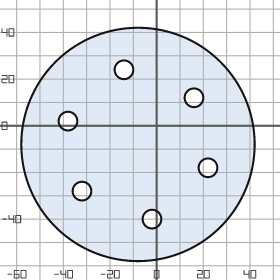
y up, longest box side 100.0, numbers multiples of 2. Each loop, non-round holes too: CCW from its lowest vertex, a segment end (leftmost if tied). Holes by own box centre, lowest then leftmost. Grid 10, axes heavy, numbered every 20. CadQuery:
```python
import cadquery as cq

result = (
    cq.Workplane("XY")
    .moveTo(-8.0, -8.0)
    .circle(50.0)
    .moveTo(-2.0, -40.0)
    .circle(4.0)
    .moveTo(-32.0, -28.0)
    .circle(4.0)
    .moveTo(22.0, -18.0)
    .circle(4.0)
    .moveTo(-38.0, 2.0)
    .circle(4.0)
    .moveTo(16.0, 12.0)
    .circle(4.0)
    .moveTo(-14.0, 24.0)
    .circle(4.0)
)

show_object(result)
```